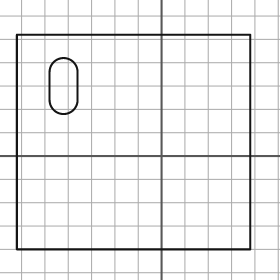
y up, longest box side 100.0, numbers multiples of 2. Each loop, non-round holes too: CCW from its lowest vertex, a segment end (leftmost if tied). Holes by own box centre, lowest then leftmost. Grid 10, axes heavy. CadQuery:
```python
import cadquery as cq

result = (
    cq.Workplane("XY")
    .moveTo(-62.0, -40.0)
    .lineTo(38.0, -40.0)
    .lineTo(38.0, 52.0)
    .lineTo(-62.0, 52.0)
    .close()
    .moveTo(-48.0, 24.0)
    .threePointArc((-42.0, 18.0), (-36.0, 24.0))
    .lineTo(-36.0, 36.0)
    .threePointArc((-42.0, 42.0), (-48.0, 36.0))
    .close()
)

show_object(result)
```